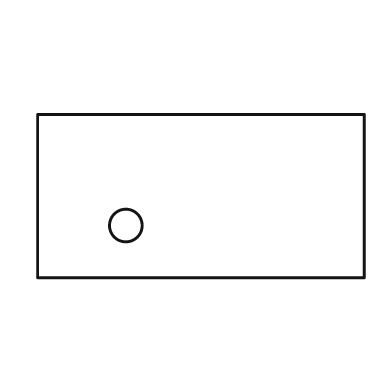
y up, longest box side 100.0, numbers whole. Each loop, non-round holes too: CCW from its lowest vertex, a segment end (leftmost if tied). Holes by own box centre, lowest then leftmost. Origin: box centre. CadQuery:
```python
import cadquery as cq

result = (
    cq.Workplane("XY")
    .moveTo(-50.0, -25.0)
    .lineTo(50.0, -25.0)
    .lineTo(50.0, 25.0)
    .lineTo(-50.0, 25.0)
    .close()
    .moveTo(-23.0, -9.0)
    .circle(5.0)
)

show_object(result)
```